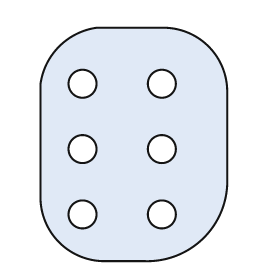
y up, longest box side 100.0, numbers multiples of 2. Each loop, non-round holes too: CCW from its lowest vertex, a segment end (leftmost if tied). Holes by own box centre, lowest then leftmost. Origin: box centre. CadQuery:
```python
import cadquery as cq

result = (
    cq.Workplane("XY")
    .moveTo(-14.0, -50.0)
    .lineTo(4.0, -50.0)
    .threePointArc((30.0, -40.0), (40.0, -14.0))
    .lineTo(40.0, 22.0)
    .threePointArc((32.0, 42.0), (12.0, 50.0))
    .lineTo(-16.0, 50.0)
    .threePointArc((-32.0, 42.0), (-40.0, 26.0))
    .lineTo(-40.0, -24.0)
    .threePointArc((-32.0, -42.0), (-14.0, -50.0))
    .close()
    .moveTo(-22.0, -30.0)
    .circle(6.0)
    .moveTo(12.0, -30.0)
    .circle(6.0)
    .moveTo(-22.0, -2.0)
    .circle(6.0)
    .moveTo(12.0, -2.0)
    .circle(6.0)
    .moveTo(-22.0, 26.0)
    .circle(6.0)
    .moveTo(12.0, 26.0)
    .circle(6.0)
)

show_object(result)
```